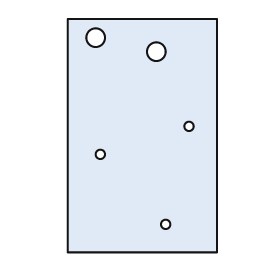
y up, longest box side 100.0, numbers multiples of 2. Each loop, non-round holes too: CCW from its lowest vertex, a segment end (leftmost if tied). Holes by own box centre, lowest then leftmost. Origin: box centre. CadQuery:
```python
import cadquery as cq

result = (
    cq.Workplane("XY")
    .moveTo(-32.0, -50.0)
    .lineTo(32.0, -50.0)
    .lineTo(32.0, 50.0)
    .lineTo(-32.0, 50.0)
    .close()
    .moveTo(10.0, -38.0)
    .circle(2.0)
    .moveTo(-18.0, -8.0)
    .circle(2.0)
    .moveTo(20.0, 4.0)
    .circle(2.0)
    .moveTo(6.0, 36.0)
    .circle(4.0)
    .moveTo(-20.0, 42.0)
    .circle(4.0)
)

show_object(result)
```